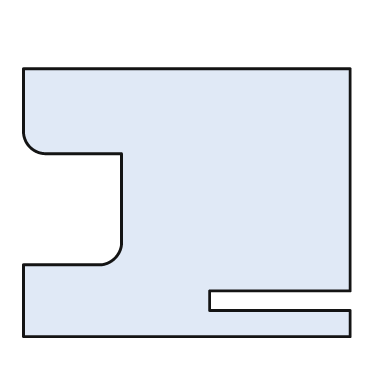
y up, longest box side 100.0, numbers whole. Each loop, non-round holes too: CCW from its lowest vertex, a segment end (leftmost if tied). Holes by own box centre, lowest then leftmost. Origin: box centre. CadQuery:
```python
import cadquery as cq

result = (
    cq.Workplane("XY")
    .moveTo(-50.0, -41.0)
    .lineTo(50.0, -41.0)
    .lineTo(50.0, -33.0)
    .lineTo(7.0, -33.0)
    .lineTo(7.0, -27.0)
    .lineTo(50.0, -27.0)
    .lineTo(50.0, 41.0)
    .lineTo(-50.0, 41.0)
    .lineTo(-50.0, 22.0)
    .threePointArc((-48.0, 17.0), (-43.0, 15.0))
    .lineTo(-20.0, 15.0)
    .lineTo(-20.0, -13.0)
    .threePointArc((-22.0, -17.0), (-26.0, -19.0))
    .lineTo(-50.0, -19.0)
    .close()
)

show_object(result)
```